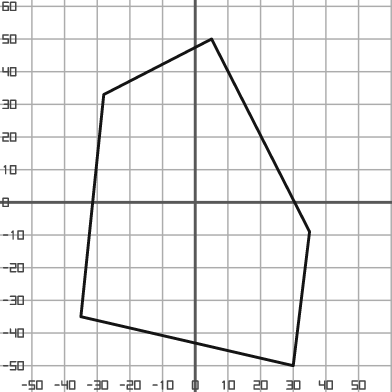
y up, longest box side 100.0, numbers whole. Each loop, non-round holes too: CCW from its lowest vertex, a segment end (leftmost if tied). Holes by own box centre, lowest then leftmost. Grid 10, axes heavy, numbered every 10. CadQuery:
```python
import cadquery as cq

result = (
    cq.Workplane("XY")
    .moveTo(30.0, -50.0)
    .lineTo(35.0, -9.0)
    .lineTo(5.0, 50.0)
    .lineTo(-28.0, 33.0)
    .lineTo(-35.0, -35.0)
    .close()
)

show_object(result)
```